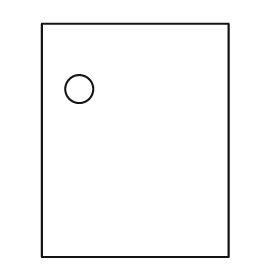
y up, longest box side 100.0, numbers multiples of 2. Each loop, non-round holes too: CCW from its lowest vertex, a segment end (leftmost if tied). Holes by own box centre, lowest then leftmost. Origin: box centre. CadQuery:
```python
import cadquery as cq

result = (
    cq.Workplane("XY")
    .moveTo(-40.0, -50.0)
    .lineTo(40.0, -50.0)
    .lineTo(40.0, 50.0)
    .lineTo(-40.0, 50.0)
    .close()
    .moveTo(-24.0, 22.0)
    .circle(6.0)
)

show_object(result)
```